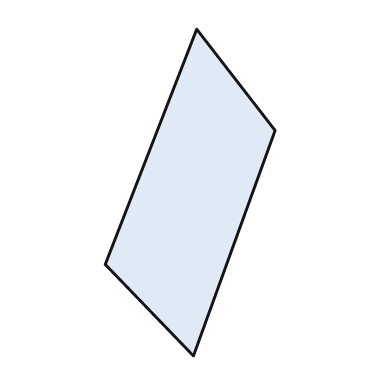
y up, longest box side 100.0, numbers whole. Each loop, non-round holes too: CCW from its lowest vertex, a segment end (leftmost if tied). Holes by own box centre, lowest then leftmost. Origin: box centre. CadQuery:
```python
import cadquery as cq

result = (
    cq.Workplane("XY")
    .moveTo(1.0, -50.0)
    .lineTo(26.0, 19.0)
    .lineTo(2.0, 50.0)
    .lineTo(-26.0, -22.0)
    .close()
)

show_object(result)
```